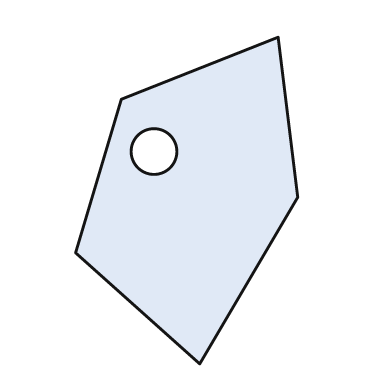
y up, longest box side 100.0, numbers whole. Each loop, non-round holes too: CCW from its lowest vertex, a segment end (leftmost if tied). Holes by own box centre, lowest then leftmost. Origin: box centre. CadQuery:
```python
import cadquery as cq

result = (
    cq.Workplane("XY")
    .moveTo(4.0, -50.0)
    .lineTo(34.0, 1.0)
    .lineTo(28.0, 50.0)
    .lineTo(-20.0, 31.0)
    .lineTo(-34.0, -16.0)
    .close()
    .moveTo(-10.0, 15.0)
    .circle(7.0)
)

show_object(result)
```